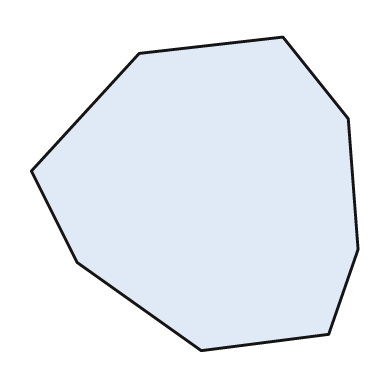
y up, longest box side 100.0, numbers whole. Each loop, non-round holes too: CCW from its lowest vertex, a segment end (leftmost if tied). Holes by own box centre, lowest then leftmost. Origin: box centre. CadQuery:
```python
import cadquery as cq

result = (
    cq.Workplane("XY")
    .moveTo(2.0, -48.0)
    .lineTo(41.0, -43.0)
    .lineTo(50.0, -17.0)
    .lineTo(47.0, 23.0)
    .lineTo(27.0, 48.0)
    .lineTo(-17.0, 43.0)
    .lineTo(-50.0, 7.0)
    .lineTo(-36.0, -21.0)
    .close()
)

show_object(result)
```